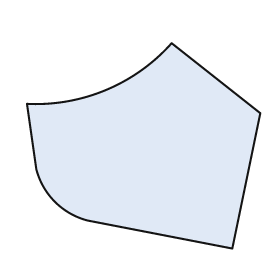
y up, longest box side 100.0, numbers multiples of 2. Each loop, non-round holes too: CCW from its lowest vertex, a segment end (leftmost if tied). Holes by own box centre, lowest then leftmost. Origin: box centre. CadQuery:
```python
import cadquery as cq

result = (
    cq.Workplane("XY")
    .moveTo(38.0, -44.0)
    .lineTo(50.0, 14.0)
    .lineTo(12.0, 44.0)
    .threePointArc((-16.0, 24.0), (-50.0, 18.0))
    .lineTo(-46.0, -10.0)
    .threePointArc((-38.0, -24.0), (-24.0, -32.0))
    .close()
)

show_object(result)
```